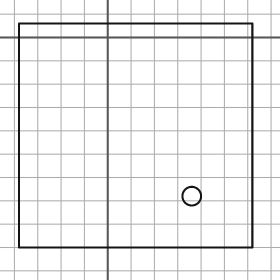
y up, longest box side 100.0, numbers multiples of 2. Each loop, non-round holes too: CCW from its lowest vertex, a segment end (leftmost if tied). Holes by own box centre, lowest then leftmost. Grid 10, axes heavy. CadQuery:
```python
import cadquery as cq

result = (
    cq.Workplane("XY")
    .moveTo(-38.0, -90.0)
    .lineTo(62.0, -90.0)
    .lineTo(62.0, 6.0)
    .lineTo(-38.0, 6.0)
    .close()
    .moveTo(36.0, -68.0)
    .circle(4.0)
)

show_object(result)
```